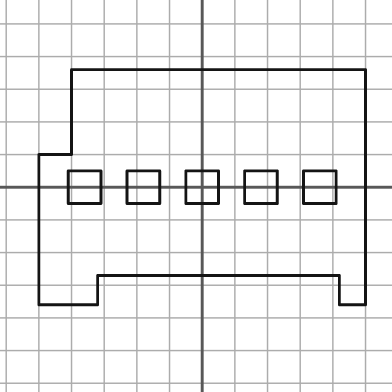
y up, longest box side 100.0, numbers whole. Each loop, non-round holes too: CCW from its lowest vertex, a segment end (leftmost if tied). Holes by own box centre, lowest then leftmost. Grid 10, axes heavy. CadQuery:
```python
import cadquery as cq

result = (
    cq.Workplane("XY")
    .moveTo(-50.0, -36.0)
    .lineTo(-32.0, -36.0)
    .lineTo(-32.0, -27.0)
    .lineTo(42.0, -27.0)
    .lineTo(42.0, -36.0)
    .lineTo(50.0, -36.0)
    .lineTo(50.0, 36.0)
    .lineTo(-40.0, 36.0)
    .lineTo(-40.0, 10.0)
    .lineTo(-50.0, 10.0)
    .close()
    .moveTo(-41.0, -5.0)
    .lineTo(-31.0, -5.0)
    .lineTo(-31.0, 5.0)
    .lineTo(-41.0, 5.0)
    .close()
    .moveTo(-23.0, -5.0)
    .lineTo(-13.0, -5.0)
    .lineTo(-13.0, 5.0)
    .lineTo(-23.0, 5.0)
    .close()
    .moveTo(-5.0, -5.0)
    .lineTo(5.0, -5.0)
    .lineTo(5.0, 5.0)
    .lineTo(-5.0, 5.0)
    .close()
    .moveTo(13.0, -5.0)
    .lineTo(23.0, -5.0)
    .lineTo(23.0, 5.0)
    .lineTo(13.0, 5.0)
    .close()
    .moveTo(31.0, -5.0)
    .lineTo(41.0, -5.0)
    .lineTo(41.0, 5.0)
    .lineTo(31.0, 5.0)
    .close()
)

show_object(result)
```